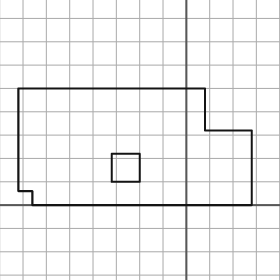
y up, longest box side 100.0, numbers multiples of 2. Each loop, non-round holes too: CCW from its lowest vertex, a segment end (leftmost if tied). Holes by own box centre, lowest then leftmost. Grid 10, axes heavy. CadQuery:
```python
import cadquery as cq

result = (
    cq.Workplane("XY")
    .moveTo(-66.0, 0.0)
    .lineTo(28.0, 0.0)
    .lineTo(28.0, 32.0)
    .lineTo(8.0, 32.0)
    .lineTo(8.0, 50.0)
    .lineTo(-72.0, 50.0)
    .lineTo(-72.0, 6.0)
    .lineTo(-66.0, 6.0)
    .close()
    .moveTo(-32.0, 10.0)
    .lineTo(-20.0, 10.0)
    .lineTo(-20.0, 22.0)
    .lineTo(-32.0, 22.0)
    .close()
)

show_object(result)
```